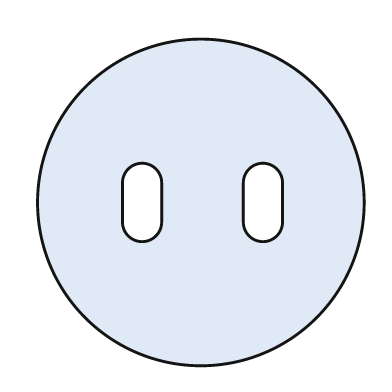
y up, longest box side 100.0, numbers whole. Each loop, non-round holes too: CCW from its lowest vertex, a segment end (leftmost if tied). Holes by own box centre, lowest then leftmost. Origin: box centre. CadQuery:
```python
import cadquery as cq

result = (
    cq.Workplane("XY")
    .moveTo(0.0, 0.0)
    .circle(50.0)
    .moveTo(-24.0, -6.0)
    .threePointArc((-18.0, -12.0), (-12.0, -6.0))
    .lineTo(-12.0, 6.0)
    .threePointArc((-18.0, 12.0), (-24.0, 6.0))
    .close()
    .moveTo(13.0, -6.0)
    .threePointArc((19.0, -12.0), (25.0, -6.0))
    .lineTo(25.0, 6.0)
    .threePointArc((19.0, 12.0), (13.0, 6.0))
    .close()
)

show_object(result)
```